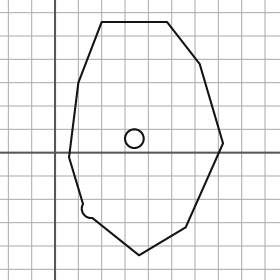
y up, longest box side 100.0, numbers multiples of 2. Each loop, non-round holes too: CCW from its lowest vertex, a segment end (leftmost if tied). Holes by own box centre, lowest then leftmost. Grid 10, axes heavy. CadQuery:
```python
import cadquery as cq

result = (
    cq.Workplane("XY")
    .moveTo(36.0, -44.0)
    .lineTo(56.0, -32.0)
    .lineTo(72.0, 4.0)
    .lineTo(62.0, 38.0)
    .lineTo(48.0, 56.0)
    .lineTo(20.0, 56.0)
    .lineTo(10.0, 30.0)
    .lineTo(6.0, -2.0)
    .lineTo(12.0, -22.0)
    .threePointArc((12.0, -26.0), (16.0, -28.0))
    .close()
    .moveTo(34.0, 6.0)
    .circle(4.0)
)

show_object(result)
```